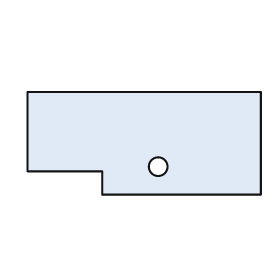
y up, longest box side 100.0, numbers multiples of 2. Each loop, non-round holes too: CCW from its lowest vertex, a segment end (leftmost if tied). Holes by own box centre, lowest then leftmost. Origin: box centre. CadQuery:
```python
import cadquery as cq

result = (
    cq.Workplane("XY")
    .moveTo(-18.0, -22.0)
    .lineTo(50.0, -22.0)
    .lineTo(50.0, 22.0)
    .lineTo(-50.0, 22.0)
    .lineTo(-50.0, -12.0)
    .lineTo(-18.0, -12.0)
    .close()
    .moveTo(6.0, -10.0)
    .circle(4.0)
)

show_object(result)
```